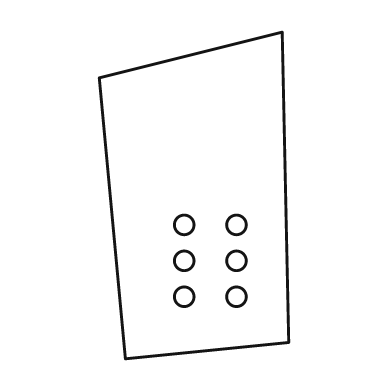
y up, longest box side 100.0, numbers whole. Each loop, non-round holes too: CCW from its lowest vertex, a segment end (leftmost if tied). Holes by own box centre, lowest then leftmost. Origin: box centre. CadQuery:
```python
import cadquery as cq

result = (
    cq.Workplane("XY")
    .moveTo(-21.0, -50.0)
    .lineTo(29.0, -45.0)
    .lineTo(27.0, 50.0)
    .lineTo(-29.0, 36.0)
    .close()
    .moveTo(-3.0, -31.0)
    .circle(3.0)
    .moveTo(13.0, -31.0)
    .circle(3.0)
    .moveTo(-3.0, -20.0)
    .circle(3.0)
    .moveTo(13.0, -20.0)
    .circle(3.0)
    .moveTo(-3.0, -9.0)
    .circle(3.0)
    .moveTo(13.0, -9.0)
    .circle(3.0)
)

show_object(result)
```